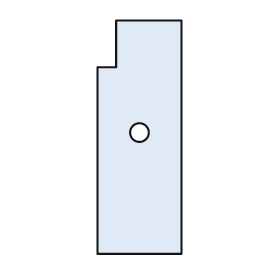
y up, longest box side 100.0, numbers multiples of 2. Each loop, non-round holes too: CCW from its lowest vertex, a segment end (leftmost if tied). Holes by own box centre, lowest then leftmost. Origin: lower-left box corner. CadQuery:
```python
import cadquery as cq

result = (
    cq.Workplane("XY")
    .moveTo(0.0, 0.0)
    .lineTo(36.0, 0.0)
    .lineTo(36.0, 100.0)
    .lineTo(8.0, 100.0)
    .lineTo(8.0, 80.0)
    .lineTo(0.0, 80.0)
    .close()
    .moveTo(18.0, 52.0)
    .circle(4.0)
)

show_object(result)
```